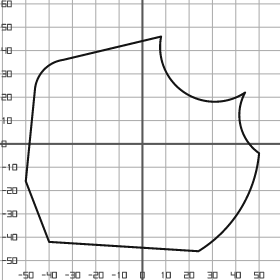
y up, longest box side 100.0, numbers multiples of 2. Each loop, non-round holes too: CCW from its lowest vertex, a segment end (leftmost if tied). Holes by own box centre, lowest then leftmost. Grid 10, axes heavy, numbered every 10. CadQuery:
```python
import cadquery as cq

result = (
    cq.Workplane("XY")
    .moveTo(24.0, -46.0)
    .threePointArc((42.0, -28.0), (50.0, -4.0))
    .threePointArc((42.0, 8.0), (44.0, 22.0))
    .threePointArc((18.0, 22.0), (8.0, 46.0))
    .lineTo(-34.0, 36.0)
    .threePointArc((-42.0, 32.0), (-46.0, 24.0))
    .lineTo(-50.0, -16.0)
    .lineTo(-40.0, -42.0)
    .close()
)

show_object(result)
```